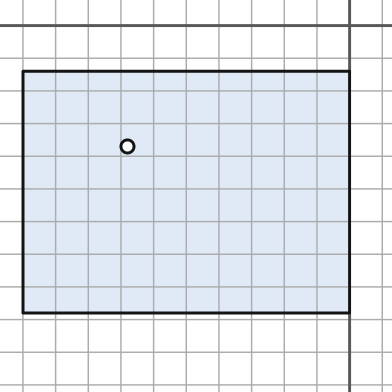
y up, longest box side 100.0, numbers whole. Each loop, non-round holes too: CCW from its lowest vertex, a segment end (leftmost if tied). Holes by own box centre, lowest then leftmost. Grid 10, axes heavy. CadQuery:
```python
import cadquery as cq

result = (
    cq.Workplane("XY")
    .moveTo(-100.0, -88.0)
    .lineTo(0.0, -88.0)
    .lineTo(0.0, -14.0)
    .lineTo(-100.0, -14.0)
    .close()
    .moveTo(-68.0, -37.0)
    .circle(2.0)
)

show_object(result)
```